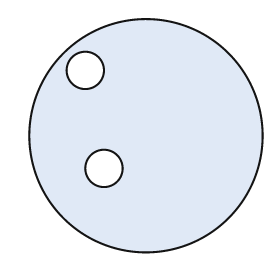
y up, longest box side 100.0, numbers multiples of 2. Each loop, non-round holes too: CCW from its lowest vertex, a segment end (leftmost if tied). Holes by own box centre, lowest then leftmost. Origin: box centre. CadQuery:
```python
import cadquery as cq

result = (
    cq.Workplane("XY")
    .moveTo(0.0, 0.0)
    .circle(50.0)
    .moveTo(-18.0, -14.0)
    .circle(8.0)
    .moveTo(-26.0, 28.0)
    .circle(8.0)
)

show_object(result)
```